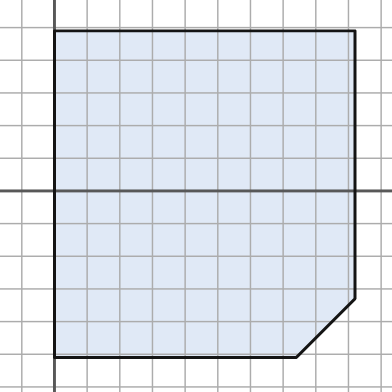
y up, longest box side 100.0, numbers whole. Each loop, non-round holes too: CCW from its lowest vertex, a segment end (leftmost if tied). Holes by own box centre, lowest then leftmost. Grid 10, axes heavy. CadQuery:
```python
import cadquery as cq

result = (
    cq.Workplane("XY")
    .moveTo(0.0, -51.0)
    .lineTo(74.0, -51.0)
    .lineTo(92.0, -33.0)
    .lineTo(92.0, 49.0)
    .lineTo(0.0, 49.0)
    .close()
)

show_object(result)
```